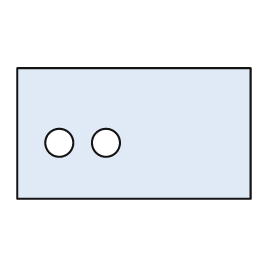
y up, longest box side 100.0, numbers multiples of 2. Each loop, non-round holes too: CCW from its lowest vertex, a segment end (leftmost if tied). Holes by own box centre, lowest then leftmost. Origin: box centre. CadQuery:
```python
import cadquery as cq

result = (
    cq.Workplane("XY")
    .moveTo(-50.0, -28.0)
    .lineTo(50.0, -28.0)
    .lineTo(50.0, 28.0)
    .lineTo(-50.0, 28.0)
    .close()
    .moveTo(-32.0, -4.0)
    .circle(6.0)
    .moveTo(-12.0, -4.0)
    .circle(6.0)
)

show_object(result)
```